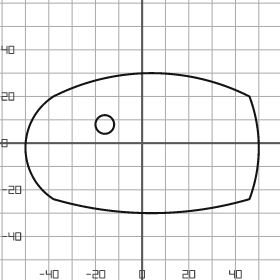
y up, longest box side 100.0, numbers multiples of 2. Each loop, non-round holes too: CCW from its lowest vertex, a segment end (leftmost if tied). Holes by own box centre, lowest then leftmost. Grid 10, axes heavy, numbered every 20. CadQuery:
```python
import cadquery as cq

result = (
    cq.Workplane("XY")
    .moveTo(-38.0, -24.0)
    .threePointArc((4.0, -30.0), (46.0, -24.0))
    .threePointArc((50.0, -2.0), (46.0, 20.0))
    .threePointArc((4.0, 30.0), (-38.0, 20.0))
    .threePointArc((-50.0, -2.0), (-38.0, -24.0))
    .close()
    .moveTo(-16.0, 8.0)
    .circle(4.0)
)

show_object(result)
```